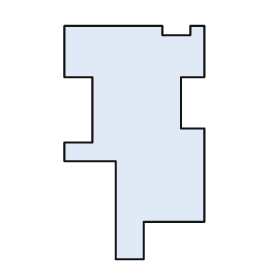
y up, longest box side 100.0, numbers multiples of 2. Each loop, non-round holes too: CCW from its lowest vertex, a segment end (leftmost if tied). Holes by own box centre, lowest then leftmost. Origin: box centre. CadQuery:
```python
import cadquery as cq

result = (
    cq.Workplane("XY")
    .moveTo(-8.0, -50.0)
    .lineTo(4.0, -50.0)
    .lineTo(4.0, -34.0)
    .lineTo(30.0, -34.0)
    .lineTo(30.0, 6.0)
    .lineTo(20.0, 6.0)
    .lineTo(20.0, 28.0)
    .lineTo(30.0, 28.0)
    .lineTo(30.0, 50.0)
    .lineTo(24.0, 50.0)
    .lineTo(24.0, 46.0)
    .lineTo(12.0, 46.0)
    .lineTo(12.0, 50.0)
    .lineTo(-30.0, 50.0)
    .lineTo(-30.0, 28.0)
    .lineTo(-18.0, 28.0)
    .lineTo(-18.0, 0.0)
    .lineTo(-30.0, 0.0)
    .lineTo(-30.0, -8.0)
    .lineTo(-8.0, -8.0)
    .close()
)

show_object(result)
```